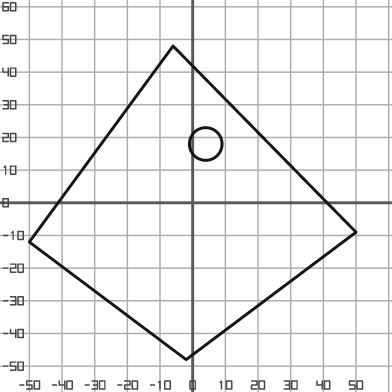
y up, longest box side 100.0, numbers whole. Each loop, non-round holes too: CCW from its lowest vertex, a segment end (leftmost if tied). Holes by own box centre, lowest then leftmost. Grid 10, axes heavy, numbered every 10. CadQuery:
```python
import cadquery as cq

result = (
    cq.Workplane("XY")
    .moveTo(-2.0, -48.0)
    .lineTo(50.0, -9.0)
    .lineTo(-6.0, 48.0)
    .lineTo(-50.0, -12.0)
    .close()
    .moveTo(4.0, 18.0)
    .circle(5.0)
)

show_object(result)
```